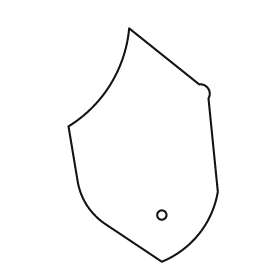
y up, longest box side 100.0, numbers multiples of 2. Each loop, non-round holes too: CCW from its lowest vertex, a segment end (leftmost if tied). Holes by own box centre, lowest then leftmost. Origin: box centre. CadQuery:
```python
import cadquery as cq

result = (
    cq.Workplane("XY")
    .moveTo(8.0, -50.0)
    .threePointArc((24.0, -38.0), (32.0, -20.0))
    .lineTo(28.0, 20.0)
    .threePointArc((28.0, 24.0), (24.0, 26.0))
    .lineTo(-6.0, 50.0)
    .threePointArc((-14.0, 26.0), (-32.0, 8.0))
    .lineTo(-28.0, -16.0)
    .threePointArc((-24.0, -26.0), (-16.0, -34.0))
    .close()
    .moveTo(8.0, -30.0)
    .circle(2.0)
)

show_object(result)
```